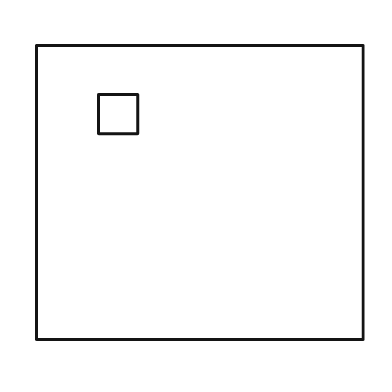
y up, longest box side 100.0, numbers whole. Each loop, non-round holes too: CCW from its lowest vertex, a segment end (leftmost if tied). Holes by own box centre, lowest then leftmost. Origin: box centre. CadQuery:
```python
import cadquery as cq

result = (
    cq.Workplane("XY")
    .moveTo(-50.0, -45.0)
    .lineTo(50.0, -45.0)
    .lineTo(50.0, 45.0)
    .lineTo(-50.0, 45.0)
    .close()
    .moveTo(-31.0, 18.0)
    .lineTo(-19.0, 18.0)
    .lineTo(-19.0, 30.0)
    .lineTo(-31.0, 30.0)
    .close()
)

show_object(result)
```